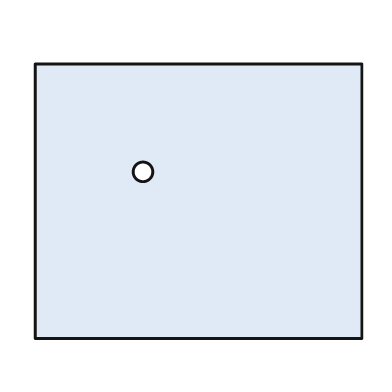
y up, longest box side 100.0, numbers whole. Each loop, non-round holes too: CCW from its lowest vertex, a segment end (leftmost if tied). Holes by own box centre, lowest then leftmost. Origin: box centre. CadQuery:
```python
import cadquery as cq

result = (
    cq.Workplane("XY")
    .moveTo(-50.0, -42.0)
    .lineTo(50.0, -42.0)
    .lineTo(50.0, 42.0)
    .lineTo(-50.0, 42.0)
    .close()
    .moveTo(-17.0, 9.0)
    .circle(3.0)
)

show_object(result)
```